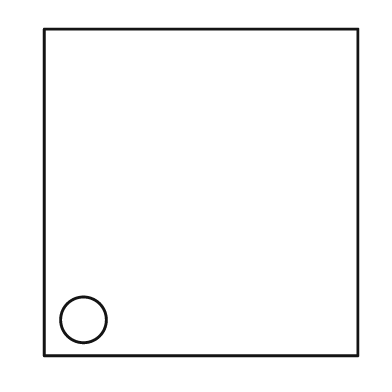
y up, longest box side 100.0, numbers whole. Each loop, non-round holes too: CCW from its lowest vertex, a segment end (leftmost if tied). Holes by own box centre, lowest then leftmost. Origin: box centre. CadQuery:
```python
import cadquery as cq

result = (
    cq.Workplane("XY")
    .moveTo(-48.0, -50.0)
    .lineTo(48.0, -50.0)
    .lineTo(48.0, 50.0)
    .lineTo(-48.0, 50.0)
    .close()
    .moveTo(-36.0, -39.0)
    .circle(7.0)
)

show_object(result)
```